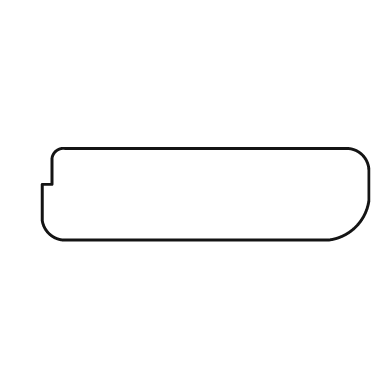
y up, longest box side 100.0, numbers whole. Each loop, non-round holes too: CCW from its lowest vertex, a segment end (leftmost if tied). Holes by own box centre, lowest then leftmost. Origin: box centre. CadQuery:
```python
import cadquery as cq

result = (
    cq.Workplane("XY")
    .moveTo(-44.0, -14.0)
    .lineTo(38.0, -14.0)
    .threePointArc((46.0, -10.0), (50.0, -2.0))
    .lineTo(50.0, 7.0)
    .threePointArc((48.0, 12.0), (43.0, 14.0))
    .lineTo(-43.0, 14.0)
    .threePointArc((-46.0, 13.0), (-47.0, 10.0))
    .lineTo(-47.0, 3.0)
    .lineTo(-50.0, 3.0)
    .lineTo(-50.0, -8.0)
    .threePointArc((-48.0, -12.0), (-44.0, -14.0))
    .close()
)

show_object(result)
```